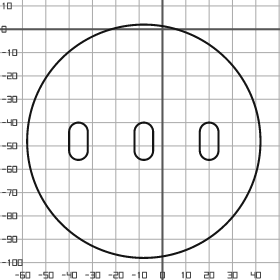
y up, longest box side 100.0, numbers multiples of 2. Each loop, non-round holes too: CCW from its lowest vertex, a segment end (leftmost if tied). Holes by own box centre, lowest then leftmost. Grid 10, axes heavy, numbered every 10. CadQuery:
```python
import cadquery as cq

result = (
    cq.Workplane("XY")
    .moveTo(-8.0, -48.0)
    .circle(50.0)
    .moveTo(-40.0, -52.0)
    .threePointArc((-36.0, -56.0), (-32.0, -52.0))
    .lineTo(-32.0, -44.0)
    .threePointArc((-36.0, -40.0), (-40.0, -44.0))
    .close()
    .moveTo(-12.0, -52.0)
    .threePointArc((-8.0, -56.0), (-4.0, -52.0))
    .lineTo(-4.0, -44.0)
    .threePointArc((-8.0, -40.0), (-12.0, -44.0))
    .close()
    .moveTo(16.0, -52.0)
    .threePointArc((20.0, -56.0), (24.0, -52.0))
    .lineTo(24.0, -44.0)
    .threePointArc((20.0, -40.0), (16.0, -44.0))
    .close()
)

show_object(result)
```